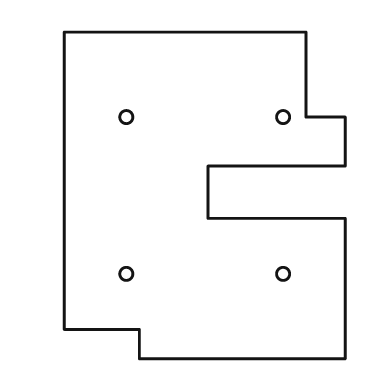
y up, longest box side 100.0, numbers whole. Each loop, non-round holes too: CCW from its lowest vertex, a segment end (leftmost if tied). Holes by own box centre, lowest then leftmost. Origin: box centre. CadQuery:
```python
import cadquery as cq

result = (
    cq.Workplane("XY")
    .moveTo(-20.0, -50.0)
    .lineTo(43.0, -50.0)
    .lineTo(43.0, -7.0)
    .lineTo(1.0, -7.0)
    .lineTo(1.0, 9.0)
    .lineTo(43.0, 9.0)
    .lineTo(43.0, 24.0)
    .lineTo(31.0, 24.0)
    .lineTo(31.0, 50.0)
    .lineTo(-43.0, 50.0)
    .lineTo(-43.0, -41.0)
    .lineTo(-20.0, -41.0)
    .close()
    .moveTo(-24.0, -24.0)
    .circle(2.0)
    .moveTo(24.0, -24.0)
    .circle(2.0)
    .moveTo(-24.0, 24.0)
    .circle(2.0)
    .moveTo(24.0, 24.0)
    .circle(2.0)
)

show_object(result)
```